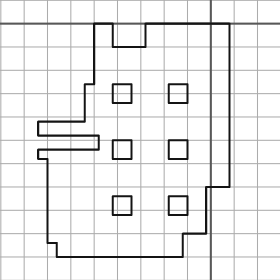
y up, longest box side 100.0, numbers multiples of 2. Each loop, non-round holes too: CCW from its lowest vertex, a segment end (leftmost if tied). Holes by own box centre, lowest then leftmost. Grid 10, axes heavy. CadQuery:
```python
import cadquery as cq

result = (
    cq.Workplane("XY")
    .moveTo(-66.0, -100.0)
    .lineTo(-12.0, -100.0)
    .lineTo(-12.0, -90.0)
    .lineTo(-2.0, -90.0)
    .lineTo(-2.0, -70.0)
    .lineTo(8.0, -70.0)
    .lineTo(8.0, 0.0)
    .lineTo(-28.0, 0.0)
    .lineTo(-28.0, -10.0)
    .lineTo(-42.0, -10.0)
    .lineTo(-42.0, 0.0)
    .lineTo(-50.0, 0.0)
    .lineTo(-50.0, -26.0)
    .lineTo(-54.0, -26.0)
    .lineTo(-54.0, -42.0)
    .lineTo(-74.0, -42.0)
    .lineTo(-74.0, -48.0)
    .lineTo(-48.0, -48.0)
    .lineTo(-48.0, -54.0)
    .lineTo(-74.0, -54.0)
    .lineTo(-74.0, -58.0)
    .lineTo(-70.0, -58.0)
    .lineTo(-70.0, -94.0)
    .lineTo(-66.0, -94.0)
    .close()
    .moveTo(-42.0, -82.0)
    .lineTo(-34.0, -82.0)
    .lineTo(-34.0, -74.0)
    .lineTo(-42.0, -74.0)
    .close()
    .moveTo(-18.0, -82.0)
    .lineTo(-10.0, -82.0)
    .lineTo(-10.0, -74.0)
    .lineTo(-18.0, -74.0)
    .close()
    .moveTo(-42.0, -58.0)
    .lineTo(-34.0, -58.0)
    .lineTo(-34.0, -50.0)
    .lineTo(-42.0, -50.0)
    .close()
    .moveTo(-18.0, -58.0)
    .lineTo(-10.0, -58.0)
    .lineTo(-10.0, -50.0)
    .lineTo(-18.0, -50.0)
    .close()
    .moveTo(-42.0, -34.0)
    .lineTo(-34.0, -34.0)
    .lineTo(-34.0, -26.0)
    .lineTo(-42.0, -26.0)
    .close()
    .moveTo(-18.0, -34.0)
    .lineTo(-10.0, -34.0)
    .lineTo(-10.0, -26.0)
    .lineTo(-18.0, -26.0)
    .close()
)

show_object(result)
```